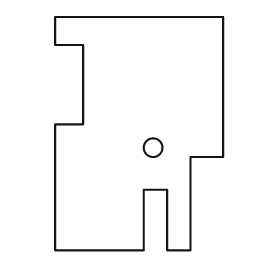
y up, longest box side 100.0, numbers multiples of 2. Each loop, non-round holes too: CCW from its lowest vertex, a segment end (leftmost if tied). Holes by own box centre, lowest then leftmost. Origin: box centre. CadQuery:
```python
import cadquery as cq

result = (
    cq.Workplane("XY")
    .moveTo(-36.0, -50.0)
    .lineTo(2.0, -50.0)
    .lineTo(2.0, -24.0)
    .lineTo(12.0, -24.0)
    .lineTo(12.0, -50.0)
    .lineTo(22.0, -50.0)
    .lineTo(22.0, -10.0)
    .lineTo(36.0, -10.0)
    .lineTo(36.0, 50.0)
    .lineTo(-36.0, 50.0)
    .lineTo(-36.0, 38.0)
    .lineTo(-24.0, 38.0)
    .lineTo(-24.0, 4.0)
    .lineTo(-36.0, 4.0)
    .close()
    .moveTo(6.0, -6.0)
    .circle(4.0)
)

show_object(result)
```